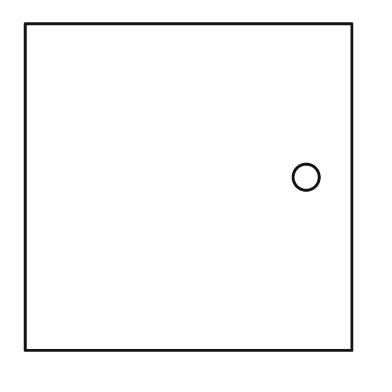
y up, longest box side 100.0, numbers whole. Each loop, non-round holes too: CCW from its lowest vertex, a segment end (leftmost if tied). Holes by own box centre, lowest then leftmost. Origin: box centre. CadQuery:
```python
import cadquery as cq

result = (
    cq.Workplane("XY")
    .moveTo(-50.0, -50.0)
    .lineTo(50.0, -50.0)
    .lineTo(50.0, 50.0)
    .lineTo(-50.0, 50.0)
    .close()
    .moveTo(36.0, 3.0)
    .circle(4.0)
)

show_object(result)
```